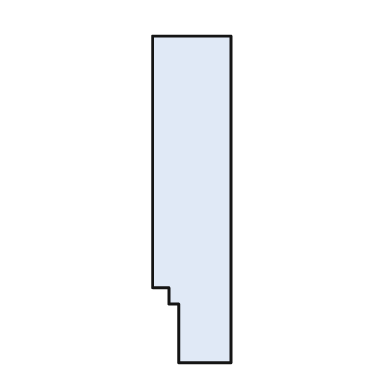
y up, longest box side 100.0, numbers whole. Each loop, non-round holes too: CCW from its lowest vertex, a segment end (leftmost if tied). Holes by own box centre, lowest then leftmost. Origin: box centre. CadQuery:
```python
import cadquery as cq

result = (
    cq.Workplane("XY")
    .moveTo(-4.0, -50.0)
    .lineTo(12.0, -50.0)
    .lineTo(12.0, 50.0)
    .lineTo(-12.0, 50.0)
    .lineTo(-12.0, -27.0)
    .lineTo(-7.0, -27.0)
    .lineTo(-7.0, -32.0)
    .lineTo(-4.0, -32.0)
    .close()
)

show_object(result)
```